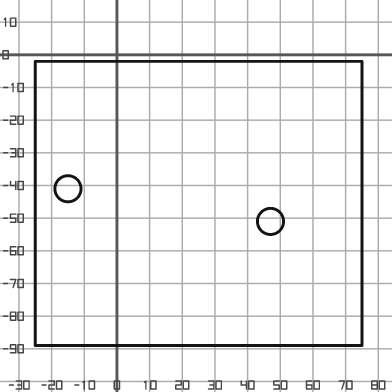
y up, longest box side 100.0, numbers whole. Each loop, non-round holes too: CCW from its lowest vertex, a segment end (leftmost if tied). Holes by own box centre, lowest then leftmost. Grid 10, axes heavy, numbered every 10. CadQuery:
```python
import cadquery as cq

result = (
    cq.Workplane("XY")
    .moveTo(-25.0, -89.0)
    .lineTo(75.0, -89.0)
    .lineTo(75.0, -2.0)
    .lineTo(-25.0, -2.0)
    .close()
    .moveTo(47.0, -51.0)
    .circle(4.0)
    .moveTo(-15.0, -41.0)
    .circle(4.0)
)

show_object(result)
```